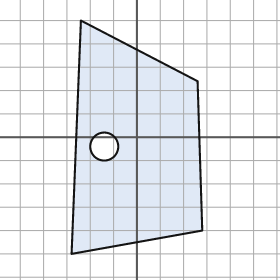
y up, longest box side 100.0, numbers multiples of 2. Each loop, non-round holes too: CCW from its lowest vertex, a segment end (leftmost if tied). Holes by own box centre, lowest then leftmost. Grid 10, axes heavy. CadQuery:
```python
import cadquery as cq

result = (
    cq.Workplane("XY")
    .moveTo(-28.0, -50.0)
    .lineTo(28.0, -40.0)
    .lineTo(26.0, 24.0)
    .lineTo(-24.0, 50.0)
    .close()
    .moveTo(-14.0, -4.0)
    .circle(6.0)
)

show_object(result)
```